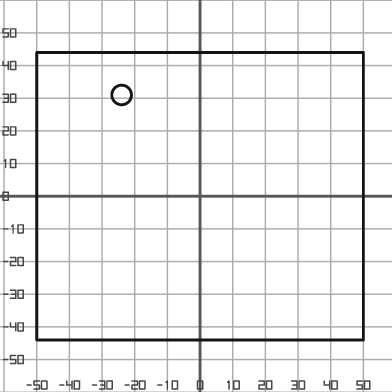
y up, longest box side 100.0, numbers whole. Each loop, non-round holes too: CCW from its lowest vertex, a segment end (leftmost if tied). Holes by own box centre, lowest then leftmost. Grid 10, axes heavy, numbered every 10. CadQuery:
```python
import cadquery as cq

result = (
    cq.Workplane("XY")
    .moveTo(-50.0, -44.0)
    .lineTo(50.0, -44.0)
    .lineTo(50.0, 44.0)
    .lineTo(-50.0, 44.0)
    .close()
    .moveTo(-24.0, 31.0)
    .circle(3.0)
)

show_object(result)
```